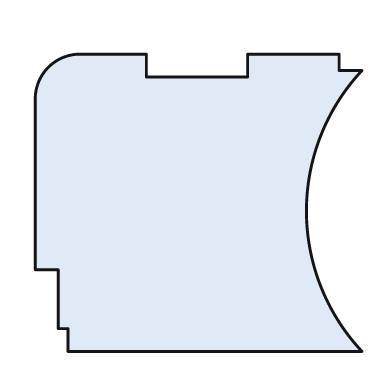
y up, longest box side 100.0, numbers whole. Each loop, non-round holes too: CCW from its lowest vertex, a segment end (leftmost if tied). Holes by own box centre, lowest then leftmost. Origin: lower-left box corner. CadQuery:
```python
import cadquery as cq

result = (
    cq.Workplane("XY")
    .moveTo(10.0, 0.0)
    .lineTo(100.0, 0.0)
    .threePointArc((83.0, 43.0), (100.0, 86.0))
    .lineTo(93.0, 86.0)
    .lineTo(93.0, 91.0)
    .lineTo(65.0, 91.0)
    .lineTo(65.0, 84.0)
    .lineTo(34.0, 84.0)
    .lineTo(34.0, 91.0)
    .lineTo(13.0, 91.0)
    .threePointArc((4.0, 87.0), (0.0, 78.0))
    .lineTo(0.0, 25.0)
    .lineTo(7.0, 25.0)
    .lineTo(7.0, 7.0)
    .lineTo(10.0, 7.0)
    .close()
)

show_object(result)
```